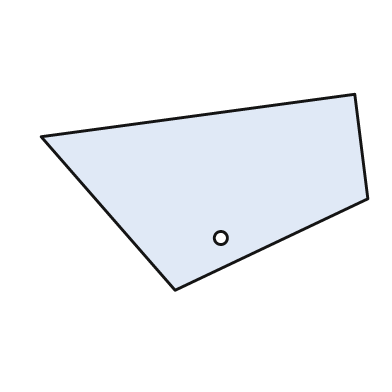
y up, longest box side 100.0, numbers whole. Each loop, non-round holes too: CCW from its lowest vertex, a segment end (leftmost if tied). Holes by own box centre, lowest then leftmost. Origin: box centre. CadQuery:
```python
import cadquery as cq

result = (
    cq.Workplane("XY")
    .moveTo(-9.0, -30.0)
    .lineTo(50.0, -2.0)
    .lineTo(46.0, 30.0)
    .lineTo(-50.0, 17.0)
    .close()
    .moveTo(5.0, -14.0)
    .circle(2.0)
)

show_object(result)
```